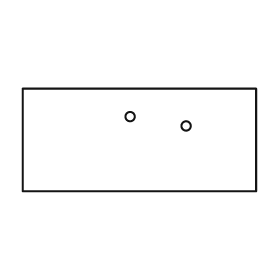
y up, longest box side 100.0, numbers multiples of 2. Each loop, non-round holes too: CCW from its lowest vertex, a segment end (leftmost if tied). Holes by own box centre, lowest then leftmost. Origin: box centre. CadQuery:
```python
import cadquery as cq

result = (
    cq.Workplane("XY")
    .moveTo(-50.0, -22.0)
    .lineTo(50.0, -22.0)
    .lineTo(50.0, 22.0)
    .lineTo(-50.0, 22.0)
    .close()
    .moveTo(20.0, 6.0)
    .circle(2.0)
    .moveTo(-4.0, 10.0)
    .circle(2.0)
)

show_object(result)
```